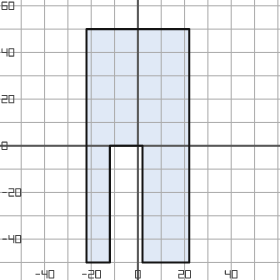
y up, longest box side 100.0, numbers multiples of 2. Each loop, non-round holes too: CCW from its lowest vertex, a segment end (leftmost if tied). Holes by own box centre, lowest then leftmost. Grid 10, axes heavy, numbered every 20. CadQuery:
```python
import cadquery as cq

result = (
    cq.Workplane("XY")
    .moveTo(-22.0, -50.0)
    .lineTo(-12.0, -50.0)
    .lineTo(-12.0, 0.0)
    .lineTo(2.0, 0.0)
    .lineTo(2.0, -50.0)
    .lineTo(22.0, -50.0)
    .lineTo(22.0, 50.0)
    .lineTo(-22.0, 50.0)
    .close()
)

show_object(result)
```